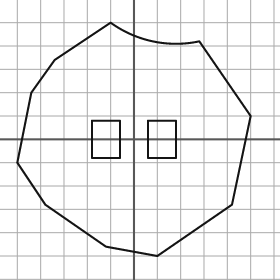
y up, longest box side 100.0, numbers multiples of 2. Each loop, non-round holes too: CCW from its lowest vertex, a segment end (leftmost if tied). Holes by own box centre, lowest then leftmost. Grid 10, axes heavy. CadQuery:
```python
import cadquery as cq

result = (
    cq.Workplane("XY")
    .moveTo(10.0, -50.0)
    .lineTo(42.0, -28.0)
    .lineTo(50.0, 10.0)
    .lineTo(28.0, 42.0)
    .threePointArc((8.0, 42.0), (-10.0, 50.0))
    .lineTo(-34.0, 34.0)
    .lineTo(-44.0, 20.0)
    .lineTo(-50.0, -10.0)
    .lineTo(-38.0, -28.0)
    .lineTo(-12.0, -46.0)
    .close()
    .moveTo(-18.0, -8.0)
    .lineTo(-6.0, -8.0)
    .lineTo(-6.0, 8.0)
    .lineTo(-18.0, 8.0)
    .close()
    .moveTo(6.0, -8.0)
    .lineTo(18.0, -8.0)
    .lineTo(18.0, 8.0)
    .lineTo(6.0, 8.0)
    .close()
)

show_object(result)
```